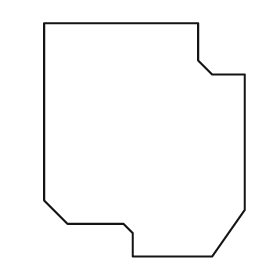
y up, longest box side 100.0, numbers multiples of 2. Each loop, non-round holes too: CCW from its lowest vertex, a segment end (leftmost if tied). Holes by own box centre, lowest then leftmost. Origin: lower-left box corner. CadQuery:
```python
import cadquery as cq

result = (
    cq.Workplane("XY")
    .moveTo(38.0, 0.0)
    .lineTo(72.0, 0.0)
    .lineTo(86.0, 20.0)
    .lineTo(86.0, 78.0)
    .lineTo(72.0, 78.0)
    .lineTo(66.0, 84.0)
    .lineTo(66.0, 100.0)
    .lineTo(0.0, 100.0)
    .lineTo(0.0, 24.0)
    .lineTo(10.0, 14.0)
    .lineTo(34.0, 14.0)
    .lineTo(38.0, 10.0)
    .close()
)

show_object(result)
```